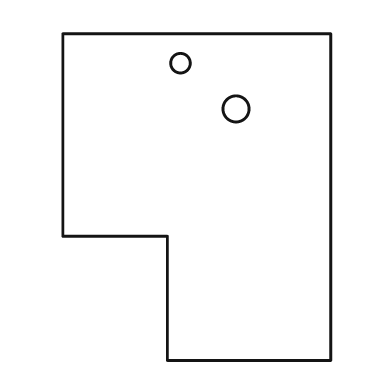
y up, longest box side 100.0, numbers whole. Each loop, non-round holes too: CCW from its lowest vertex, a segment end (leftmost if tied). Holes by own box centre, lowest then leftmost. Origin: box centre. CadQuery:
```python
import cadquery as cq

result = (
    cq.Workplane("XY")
    .moveTo(-9.0, -50.0)
    .lineTo(41.0, -50.0)
    .lineTo(41.0, 50.0)
    .lineTo(-41.0, 50.0)
    .lineTo(-41.0, -12.0)
    .lineTo(-9.0, -12.0)
    .close()
    .moveTo(12.0, 27.0)
    .circle(4.0)
    .moveTo(-5.0, 41.0)
    .circle(3.0)
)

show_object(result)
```